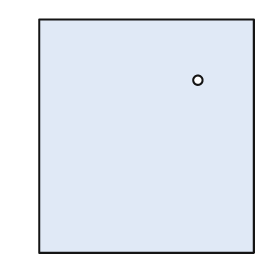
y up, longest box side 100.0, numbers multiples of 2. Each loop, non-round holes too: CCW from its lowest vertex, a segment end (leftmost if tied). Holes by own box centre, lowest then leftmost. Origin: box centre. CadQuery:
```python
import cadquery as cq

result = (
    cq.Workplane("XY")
    .moveTo(-46.0, -50.0)
    .lineTo(46.0, -50.0)
    .lineTo(46.0, 50.0)
    .lineTo(-46.0, 50.0)
    .close()
    .moveTo(22.0, 24.0)
    .circle(2.0)
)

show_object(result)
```